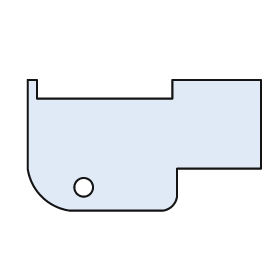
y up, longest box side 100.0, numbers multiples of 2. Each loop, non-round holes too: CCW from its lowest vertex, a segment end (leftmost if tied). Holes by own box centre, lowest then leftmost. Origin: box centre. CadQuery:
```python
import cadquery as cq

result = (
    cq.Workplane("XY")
    .moveTo(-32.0, -28.0)
    .lineTo(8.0, -28.0)
    .threePointArc((12.0, -26.0), (14.0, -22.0))
    .lineTo(14.0, -10.0)
    .lineTo(50.0, -10.0)
    .lineTo(50.0, 28.0)
    .lineTo(12.0, 28.0)
    .lineTo(12.0, 20.0)
    .lineTo(-46.0, 20.0)
    .lineTo(-46.0, 28.0)
    .lineTo(-50.0, 28.0)
    .lineTo(-50.0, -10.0)
    .threePointArc((-44.0, -22.0), (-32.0, -28.0))
    .close()
    .moveTo(-26.0, -18.0)
    .circle(4.0)
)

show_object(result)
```